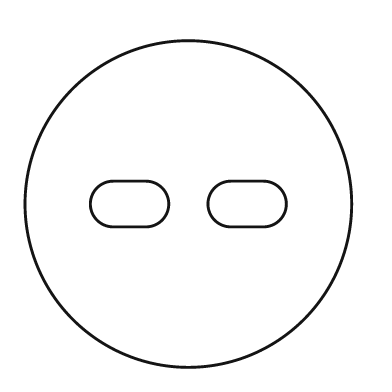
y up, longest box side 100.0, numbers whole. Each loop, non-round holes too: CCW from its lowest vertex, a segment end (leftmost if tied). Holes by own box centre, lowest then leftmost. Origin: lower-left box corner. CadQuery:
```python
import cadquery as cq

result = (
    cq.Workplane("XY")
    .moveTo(50.0, 50.0)
    .circle(50.0)
    .moveTo(27.0, 43.0)
    .lineTo(37.0, 43.0)
    .threePointArc((44.0, 50.0), (37.0, 57.0))
    .lineTo(27.0, 57.0)
    .threePointArc((20.0, 50.0), (27.0, 43.0))
    .close()
    .moveTo(63.0, 43.0)
    .lineTo(73.0, 43.0)
    .threePointArc((80.0, 50.0), (73.0, 57.0))
    .lineTo(63.0, 57.0)
    .threePointArc((56.0, 50.0), (63.0, 43.0))
    .close()
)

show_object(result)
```